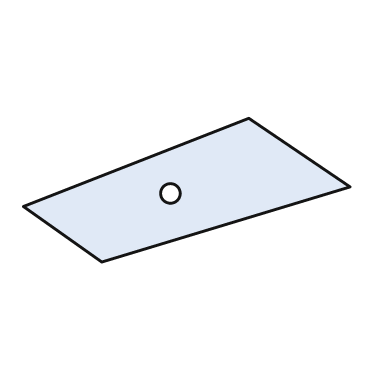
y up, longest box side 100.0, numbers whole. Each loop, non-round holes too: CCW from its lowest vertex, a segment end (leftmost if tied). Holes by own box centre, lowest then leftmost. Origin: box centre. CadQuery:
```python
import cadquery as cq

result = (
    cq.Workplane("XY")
    .moveTo(-26.0, -22.0)
    .lineTo(50.0, 1.0)
    .lineTo(19.0, 22.0)
    .lineTo(-50.0, -5.0)
    .close()
    .moveTo(-5.0, -1.0)
    .circle(3.0)
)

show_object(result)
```